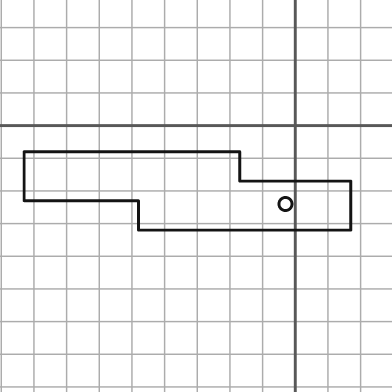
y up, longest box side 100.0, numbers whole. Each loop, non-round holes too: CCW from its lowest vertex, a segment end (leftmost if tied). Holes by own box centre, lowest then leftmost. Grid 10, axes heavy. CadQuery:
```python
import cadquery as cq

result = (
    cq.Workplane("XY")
    .moveTo(-48.0, -32.0)
    .lineTo(17.0, -32.0)
    .lineTo(17.0, -17.0)
    .lineTo(-17.0, -17.0)
    .lineTo(-17.0, -8.0)
    .lineTo(-83.0, -8.0)
    .lineTo(-83.0, -23.0)
    .lineTo(-48.0, -23.0)
    .close()
    .moveTo(-3.0, -24.0)
    .circle(2.0)
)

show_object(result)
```